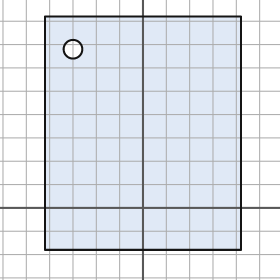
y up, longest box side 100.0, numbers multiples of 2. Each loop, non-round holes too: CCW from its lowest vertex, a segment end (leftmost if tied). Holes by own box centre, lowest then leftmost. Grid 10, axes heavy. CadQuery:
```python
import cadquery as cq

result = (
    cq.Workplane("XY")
    .moveTo(-42.0, -18.0)
    .lineTo(42.0, -18.0)
    .lineTo(42.0, 82.0)
    .lineTo(-42.0, 82.0)
    .close()
    .moveTo(-30.0, 68.0)
    .circle(4.0)
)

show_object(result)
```